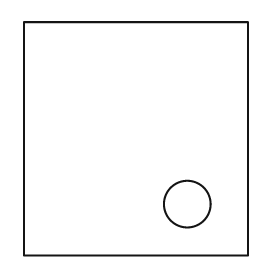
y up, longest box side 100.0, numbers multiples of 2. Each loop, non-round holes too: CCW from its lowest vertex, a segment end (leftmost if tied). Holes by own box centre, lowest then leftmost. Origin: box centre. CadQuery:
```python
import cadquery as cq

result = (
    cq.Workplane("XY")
    .moveTo(-48.0, -50.0)
    .lineTo(48.0, -50.0)
    .lineTo(48.0, 50.0)
    .lineTo(-48.0, 50.0)
    .close()
    .moveTo(22.0, -28.0)
    .circle(10.0)
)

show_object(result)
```